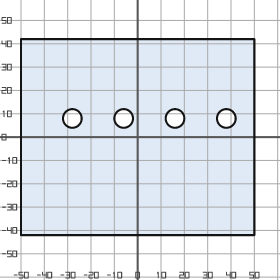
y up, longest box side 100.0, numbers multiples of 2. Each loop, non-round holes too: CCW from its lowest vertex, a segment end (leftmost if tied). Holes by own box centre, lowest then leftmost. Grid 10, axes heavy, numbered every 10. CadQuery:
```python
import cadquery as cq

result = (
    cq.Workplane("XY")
    .moveTo(-50.0, -42.0)
    .lineTo(50.0, -42.0)
    .lineTo(50.0, 42.0)
    .lineTo(-50.0, 42.0)
    .close()
    .moveTo(-28.0, 8.0)
    .circle(4.0)
    .moveTo(-6.0, 8.0)
    .circle(4.0)
    .moveTo(16.0, 8.0)
    .circle(4.0)
    .moveTo(38.0, 8.0)
    .circle(4.0)
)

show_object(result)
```